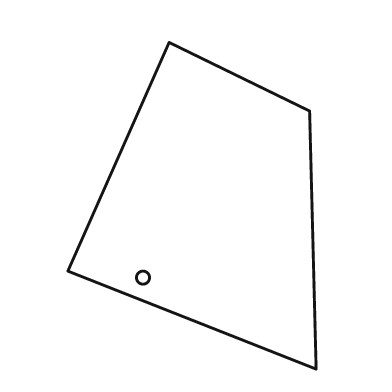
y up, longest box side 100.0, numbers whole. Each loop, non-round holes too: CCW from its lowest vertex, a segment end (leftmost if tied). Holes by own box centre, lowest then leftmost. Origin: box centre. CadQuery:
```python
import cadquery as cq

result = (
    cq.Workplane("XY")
    .moveTo(38.0, -50.0)
    .lineTo(36.0, 29.0)
    .lineTo(-7.0, 50.0)
    .lineTo(-38.0, -20.0)
    .close()
    .moveTo(-15.0, -22.0)
    .circle(2.0)
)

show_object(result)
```